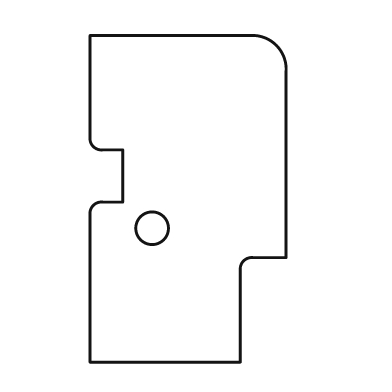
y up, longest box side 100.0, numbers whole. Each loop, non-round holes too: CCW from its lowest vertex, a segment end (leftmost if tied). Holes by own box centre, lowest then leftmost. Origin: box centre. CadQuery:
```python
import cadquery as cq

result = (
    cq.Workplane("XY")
    .moveTo(-30.0, -50.0)
    .lineTo(16.0, -50.0)
    .lineTo(16.0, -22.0)
    .threePointArc((17.0, -19.0), (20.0, -18.0))
    .lineTo(30.0, -18.0)
    .lineTo(30.0, 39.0)
    .threePointArc((27.0, 47.0), (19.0, 50.0))
    .lineTo(-30.0, 50.0)
    .lineTo(-30.0, 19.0)
    .threePointArc((-29.0, 16.0), (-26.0, 15.0))
    .lineTo(-20.0, 15.0)
    .lineTo(-20.0, -1.0)
    .lineTo(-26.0, -1.0)
    .threePointArc((-29.0, -2.0), (-30.0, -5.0))
    .close()
    .moveTo(-11.0, -9.0)
    .circle(5.0)
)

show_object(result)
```